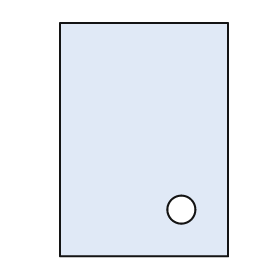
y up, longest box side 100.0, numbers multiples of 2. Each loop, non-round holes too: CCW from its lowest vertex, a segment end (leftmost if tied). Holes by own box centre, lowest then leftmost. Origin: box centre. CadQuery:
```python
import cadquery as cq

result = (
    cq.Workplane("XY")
    .moveTo(-36.0, -50.0)
    .lineTo(36.0, -50.0)
    .lineTo(36.0, 50.0)
    .lineTo(-36.0, 50.0)
    .close()
    .moveTo(16.0, -30.0)
    .circle(6.0)
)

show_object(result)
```